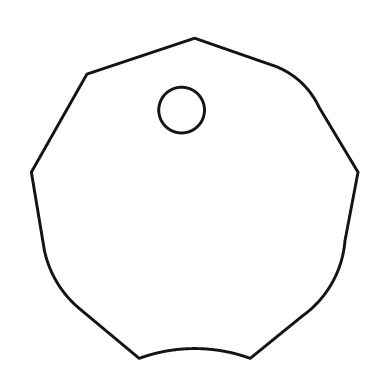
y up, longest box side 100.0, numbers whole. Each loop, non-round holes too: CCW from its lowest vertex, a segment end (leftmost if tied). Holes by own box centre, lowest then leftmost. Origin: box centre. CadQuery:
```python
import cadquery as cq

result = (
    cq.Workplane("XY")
    .moveTo(-17.0, -49.0)
    .threePointArc((0.0, -46.0), (17.0, -49.0))
    .lineTo(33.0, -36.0)
    .threePointArc((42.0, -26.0), (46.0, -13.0))
    .lineTo(50.0, 8.0)
    .lineTo(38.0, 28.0)
    .threePointArc((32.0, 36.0), (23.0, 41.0))
    .lineTo(0.0, 49.0)
    .lineTo(-33.0, 38.0)
    .lineTo(-50.0, 8.0)
    .lineTo(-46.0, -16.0)
    .threePointArc((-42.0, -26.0), (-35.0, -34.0))
    .close()
    .moveTo(-4.0, 27.0)
    .circle(7.0)
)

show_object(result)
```